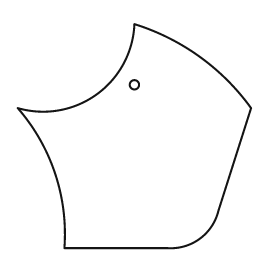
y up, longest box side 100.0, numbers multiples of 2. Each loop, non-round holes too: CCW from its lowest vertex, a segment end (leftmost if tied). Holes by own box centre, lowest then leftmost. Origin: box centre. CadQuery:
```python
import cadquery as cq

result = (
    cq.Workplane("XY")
    .moveTo(-30.0, -48.0)
    .lineTo(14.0, -48.0)
    .threePointArc((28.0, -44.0), (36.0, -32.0))
    .lineTo(50.0, 12.0)
    .threePointArc((28.0, 34.0), (0.0, 48.0))
    .threePointArc((-16.0, 18.0), (-50.0, 12.0))
    .threePointArc((-34.0, -16.0), (-30.0, -48.0))
    .close()
    .moveTo(0.0, 22.0)
    .circle(2.0)
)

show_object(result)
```